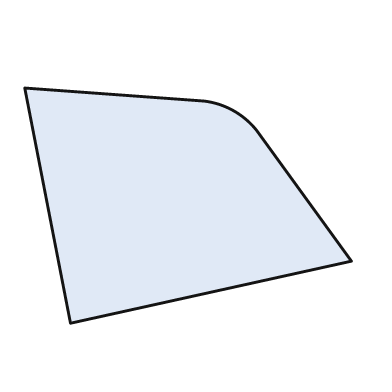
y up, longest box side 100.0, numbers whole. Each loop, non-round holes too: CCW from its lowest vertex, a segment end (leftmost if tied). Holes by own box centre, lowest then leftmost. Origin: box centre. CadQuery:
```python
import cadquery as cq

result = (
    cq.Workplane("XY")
    .moveTo(-36.0, -36.0)
    .lineTo(50.0, -17.0)
    .lineTo(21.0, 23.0)
    .threePointArc((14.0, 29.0), (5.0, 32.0))
    .lineTo(-50.0, 36.0)
    .close()
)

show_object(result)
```